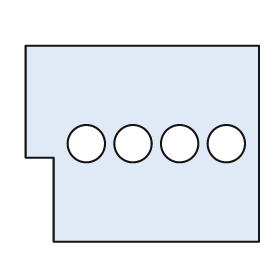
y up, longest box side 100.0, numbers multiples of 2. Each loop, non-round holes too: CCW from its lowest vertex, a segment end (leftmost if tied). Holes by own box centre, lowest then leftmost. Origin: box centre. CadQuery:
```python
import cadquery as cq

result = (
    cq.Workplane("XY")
    .moveTo(-38.0, -42.0)
    .lineTo(50.0, -42.0)
    .lineTo(50.0, 42.0)
    .lineTo(-50.0, 42.0)
    .lineTo(-50.0, -6.0)
    .lineTo(-38.0, -6.0)
    .close()
    .moveTo(-24.0, 0.0)
    .circle(8.0)
    .moveTo(-4.0, 0.0)
    .circle(8.0)
    .moveTo(16.0, 0.0)
    .circle(8.0)
    .moveTo(36.0, 0.0)
    .circle(8.0)
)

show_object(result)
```